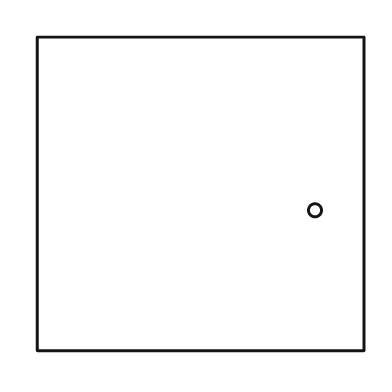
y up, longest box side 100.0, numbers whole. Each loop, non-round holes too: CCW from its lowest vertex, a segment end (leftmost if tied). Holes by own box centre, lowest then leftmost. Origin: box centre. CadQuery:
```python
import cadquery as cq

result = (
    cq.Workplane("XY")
    .moveTo(-50.0, -48.0)
    .lineTo(50.0, -48.0)
    .lineTo(50.0, 48.0)
    .lineTo(-50.0, 48.0)
    .close()
    .moveTo(35.0, -5.0)
    .circle(2.0)
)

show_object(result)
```